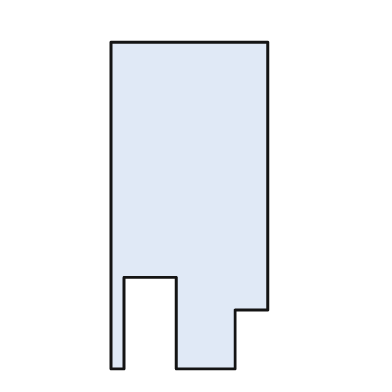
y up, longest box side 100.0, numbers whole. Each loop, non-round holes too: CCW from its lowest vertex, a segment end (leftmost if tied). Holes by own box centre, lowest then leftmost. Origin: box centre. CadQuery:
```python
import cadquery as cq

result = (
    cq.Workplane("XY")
    .moveTo(-24.0, -50.0)
    .lineTo(-20.0, -50.0)
    .lineTo(-20.0, -22.0)
    .lineTo(-4.0, -22.0)
    .lineTo(-4.0, -50.0)
    .lineTo(14.0, -50.0)
    .lineTo(14.0, -32.0)
    .lineTo(24.0, -32.0)
    .lineTo(24.0, 50.0)
    .lineTo(-24.0, 50.0)
    .close()
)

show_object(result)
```